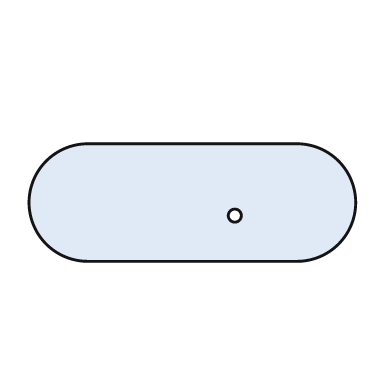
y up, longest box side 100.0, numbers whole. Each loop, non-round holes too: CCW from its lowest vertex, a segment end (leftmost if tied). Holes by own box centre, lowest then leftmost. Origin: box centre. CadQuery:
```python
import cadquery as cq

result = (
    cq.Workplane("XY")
    .moveTo(-32.0, -18.0)
    .lineTo(32.0, -18.0)
    .threePointArc((50.0, 0.0), (32.0, 18.0))
    .lineTo(-32.0, 18.0)
    .threePointArc((-50.0, 0.0), (-32.0, -18.0))
    .close()
    .moveTo(13.0, -4.0)
    .circle(2.0)
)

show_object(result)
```